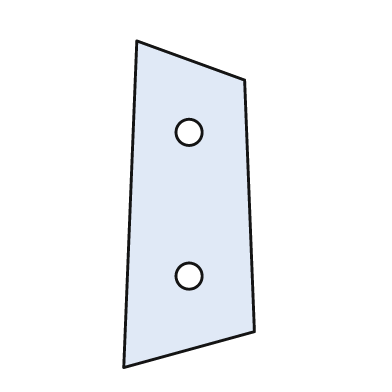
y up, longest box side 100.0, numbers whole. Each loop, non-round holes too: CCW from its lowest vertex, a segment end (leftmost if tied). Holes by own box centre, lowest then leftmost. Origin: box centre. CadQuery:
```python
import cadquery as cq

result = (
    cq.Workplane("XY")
    .moveTo(-20.0, -50.0)
    .lineTo(20.0, -39.0)
    .lineTo(17.0, 38.0)
    .lineTo(-16.0, 50.0)
    .close()
    .moveTo(0.0, -22.0)
    .circle(4.0)
    .moveTo(0.0, 22.0)
    .circle(4.0)
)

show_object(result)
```